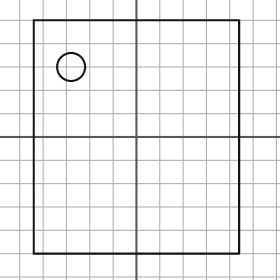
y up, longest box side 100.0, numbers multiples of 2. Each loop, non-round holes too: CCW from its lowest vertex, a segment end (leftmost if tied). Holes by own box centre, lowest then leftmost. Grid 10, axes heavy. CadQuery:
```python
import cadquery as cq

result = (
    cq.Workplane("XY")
    .moveTo(-44.0, -50.0)
    .lineTo(44.0, -50.0)
    .lineTo(44.0, 50.0)
    .lineTo(-44.0, 50.0)
    .close()
    .moveTo(-28.0, 30.0)
    .circle(6.0)
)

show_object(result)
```